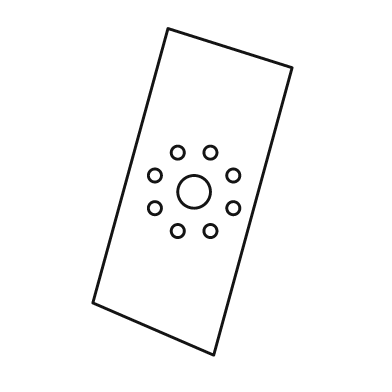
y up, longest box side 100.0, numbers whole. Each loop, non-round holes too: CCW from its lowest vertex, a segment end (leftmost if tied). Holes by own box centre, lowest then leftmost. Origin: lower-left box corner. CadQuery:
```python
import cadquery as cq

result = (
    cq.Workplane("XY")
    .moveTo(37.0, 0.0)
    .lineTo(61.0, 88.0)
    .lineTo(23.0, 100.0)
    .lineTo(0.0, 16.0)
    .close()
    .moveTo(26.0, 38.0)
    .circle(2.0)
    .moveTo(36.0, 38.0)
    .circle(2.0)
    .moveTo(19.0, 45.0)
    .circle(2.0)
    .moveTo(43.0, 45.0)
    .circle(2.0)
    .moveTo(31.0, 50.0)
    .circle(5.0)
    .moveTo(19.0, 55.0)
    .circle(2.0)
    .moveTo(43.0, 55.0)
    .circle(2.0)
    .moveTo(26.0, 62.0)
    .circle(2.0)
    .moveTo(36.0, 62.0)
    .circle(2.0)
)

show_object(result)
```